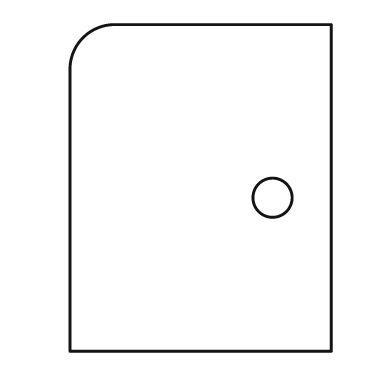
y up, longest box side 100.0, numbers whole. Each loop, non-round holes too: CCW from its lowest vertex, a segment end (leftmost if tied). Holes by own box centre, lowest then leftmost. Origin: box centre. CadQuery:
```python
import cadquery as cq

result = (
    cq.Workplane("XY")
    .moveTo(-40.0, -50.0)
    .lineTo(40.0, -50.0)
    .lineTo(40.0, 50.0)
    .lineTo(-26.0, 50.0)
    .threePointArc((-36.0, 46.0), (-40.0, 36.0))
    .close()
    .moveTo(22.0, -3.0)
    .circle(6.0)
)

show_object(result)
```